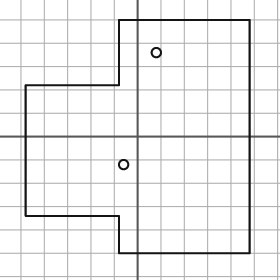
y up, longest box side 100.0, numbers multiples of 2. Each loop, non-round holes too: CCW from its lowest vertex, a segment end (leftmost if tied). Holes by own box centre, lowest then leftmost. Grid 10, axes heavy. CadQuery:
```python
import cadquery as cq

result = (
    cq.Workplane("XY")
    .moveTo(-8.0, -50.0)
    .lineTo(48.0, -50.0)
    .lineTo(48.0, 50.0)
    .lineTo(-8.0, 50.0)
    .lineTo(-8.0, 22.0)
    .lineTo(-48.0, 22.0)
    .lineTo(-48.0, -34.0)
    .lineTo(-8.0, -34.0)
    .close()
    .moveTo(-6.0, -12.0)
    .circle(2.0)
    .moveTo(8.0, 36.0)
    .circle(2.0)
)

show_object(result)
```